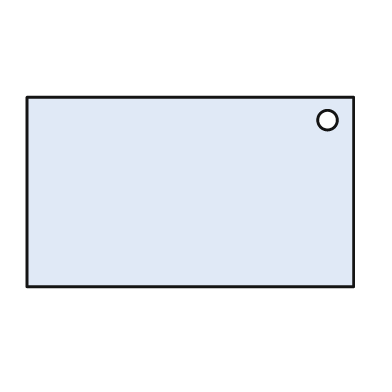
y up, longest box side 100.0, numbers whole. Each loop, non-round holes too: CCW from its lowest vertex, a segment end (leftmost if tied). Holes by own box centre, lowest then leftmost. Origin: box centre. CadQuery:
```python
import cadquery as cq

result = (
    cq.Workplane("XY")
    .moveTo(-50.0, -29.0)
    .lineTo(50.0, -29.0)
    .lineTo(50.0, 29.0)
    .lineTo(-50.0, 29.0)
    .close()
    .moveTo(42.0, 22.0)
    .circle(3.0)
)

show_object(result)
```